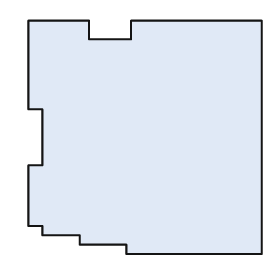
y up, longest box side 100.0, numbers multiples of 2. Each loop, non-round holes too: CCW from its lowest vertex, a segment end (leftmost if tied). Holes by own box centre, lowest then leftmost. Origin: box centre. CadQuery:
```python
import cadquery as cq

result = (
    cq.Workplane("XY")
    .moveTo(-8.0, -50.0)
    .lineTo(50.0, -50.0)
    .lineTo(50.0, 50.0)
    .lineTo(-6.0, 50.0)
    .lineTo(-6.0, 42.0)
    .lineTo(-24.0, 42.0)
    .lineTo(-24.0, 50.0)
    .lineTo(-50.0, 50.0)
    .lineTo(-50.0, 12.0)
    .lineTo(-44.0, 12.0)
    .lineTo(-44.0, -12.0)
    .lineTo(-50.0, -12.0)
    .lineTo(-50.0, -38.0)
    .lineTo(-44.0, -38.0)
    .lineTo(-44.0, -42.0)
    .lineTo(-28.0, -42.0)
    .lineTo(-28.0, -46.0)
    .lineTo(-8.0, -46.0)
    .close()
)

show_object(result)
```